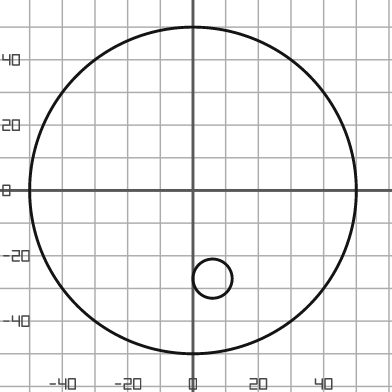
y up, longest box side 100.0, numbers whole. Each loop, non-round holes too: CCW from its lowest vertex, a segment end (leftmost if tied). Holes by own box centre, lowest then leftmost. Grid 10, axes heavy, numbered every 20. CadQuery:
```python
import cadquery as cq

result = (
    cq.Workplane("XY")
    .moveTo(0.0, 0.0)
    .circle(50.0)
    .moveTo(6.0, -27.0)
    .circle(6.0)
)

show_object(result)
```